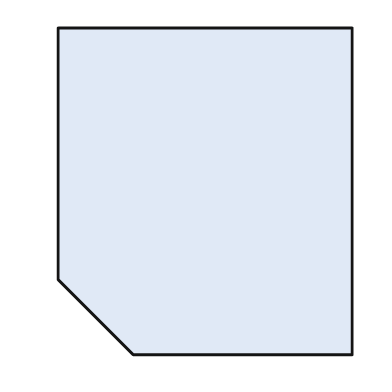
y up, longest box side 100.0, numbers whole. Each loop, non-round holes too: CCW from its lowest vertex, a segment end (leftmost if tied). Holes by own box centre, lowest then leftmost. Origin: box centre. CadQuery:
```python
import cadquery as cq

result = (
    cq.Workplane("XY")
    .moveTo(-22.0, -50.0)
    .lineTo(45.0, -50.0)
    .lineTo(45.0, 50.0)
    .lineTo(-45.0, 50.0)
    .lineTo(-45.0, -27.0)
    .close()
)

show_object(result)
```